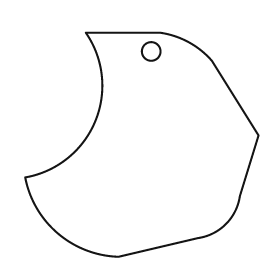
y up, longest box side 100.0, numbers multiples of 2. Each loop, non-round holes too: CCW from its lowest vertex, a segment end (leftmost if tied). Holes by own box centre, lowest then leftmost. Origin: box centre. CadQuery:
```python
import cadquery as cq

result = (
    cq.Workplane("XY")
    .moveTo(-10.0, -48.0)
    .lineTo(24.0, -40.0)
    .threePointArc((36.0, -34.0), (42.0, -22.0))
    .lineTo(50.0, 4.0)
    .lineTo(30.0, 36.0)
    .threePointArc((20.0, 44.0), (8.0, 48.0))
    .lineTo(-24.0, 48.0)
    .threePointArc((-20.0, 10.0), (-50.0, -14.0))
    .threePointArc((-36.0, -38.0), (-10.0, -48.0))
    .close()
    .moveTo(4.0, 40.0)
    .circle(4.0)
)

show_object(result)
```